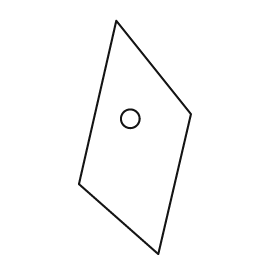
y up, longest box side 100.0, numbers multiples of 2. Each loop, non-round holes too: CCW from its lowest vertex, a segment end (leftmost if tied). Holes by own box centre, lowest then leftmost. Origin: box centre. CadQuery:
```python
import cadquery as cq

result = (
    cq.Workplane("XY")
    .moveTo(10.0, -50.0)
    .lineTo(24.0, 10.0)
    .lineTo(-8.0, 50.0)
    .lineTo(-24.0, -20.0)
    .close()
    .moveTo(-2.0, 8.0)
    .circle(4.0)
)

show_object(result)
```